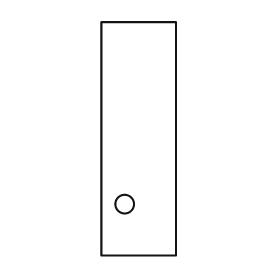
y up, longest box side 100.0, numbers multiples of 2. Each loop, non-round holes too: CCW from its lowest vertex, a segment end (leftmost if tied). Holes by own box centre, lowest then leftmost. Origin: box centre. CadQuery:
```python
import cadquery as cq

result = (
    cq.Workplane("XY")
    .moveTo(-16.0, -50.0)
    .lineTo(16.0, -50.0)
    .lineTo(16.0, 50.0)
    .lineTo(-16.0, 50.0)
    .close()
    .moveTo(-6.0, -28.0)
    .circle(4.0)
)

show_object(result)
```